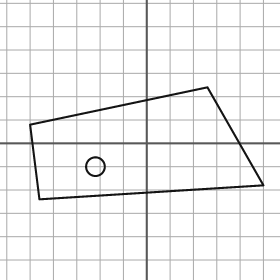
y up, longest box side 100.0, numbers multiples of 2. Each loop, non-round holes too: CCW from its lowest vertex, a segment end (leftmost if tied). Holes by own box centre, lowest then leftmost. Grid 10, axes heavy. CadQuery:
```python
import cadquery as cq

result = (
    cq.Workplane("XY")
    .moveTo(-46.0, -24.0)
    .lineTo(50.0, -18.0)
    .lineTo(26.0, 24.0)
    .lineTo(-50.0, 8.0)
    .close()
    .moveTo(-22.0, -10.0)
    .circle(4.0)
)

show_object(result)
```